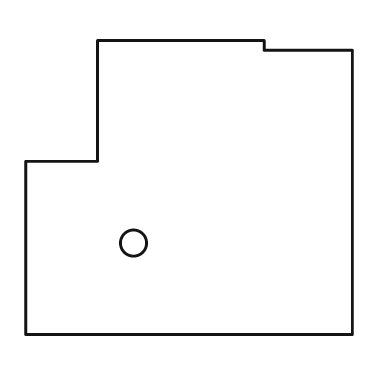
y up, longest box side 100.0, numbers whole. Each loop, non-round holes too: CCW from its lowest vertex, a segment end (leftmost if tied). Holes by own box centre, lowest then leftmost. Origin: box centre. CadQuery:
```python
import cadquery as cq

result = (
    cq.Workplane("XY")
    .moveTo(-50.0, -45.0)
    .lineTo(50.0, -45.0)
    .lineTo(50.0, 42.0)
    .lineTo(23.0, 42.0)
    .lineTo(23.0, 45.0)
    .lineTo(-28.0, 45.0)
    .lineTo(-28.0, 8.0)
    .lineTo(-50.0, 8.0)
    .close()
    .moveTo(-17.0, -17.0)
    .circle(4.0)
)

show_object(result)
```